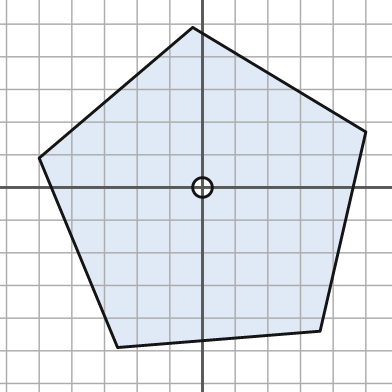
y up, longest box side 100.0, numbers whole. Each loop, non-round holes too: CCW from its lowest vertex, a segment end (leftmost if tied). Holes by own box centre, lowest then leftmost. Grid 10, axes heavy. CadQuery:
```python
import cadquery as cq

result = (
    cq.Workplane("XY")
    .moveTo(-26.0, -49.0)
    .lineTo(36.0, -44.0)
    .lineTo(50.0, 17.0)
    .lineTo(-3.0, 49.0)
    .lineTo(-50.0, 9.0)
    .close()
    .moveTo(0.0, 0.0)
    .circle(3.0)
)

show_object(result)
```